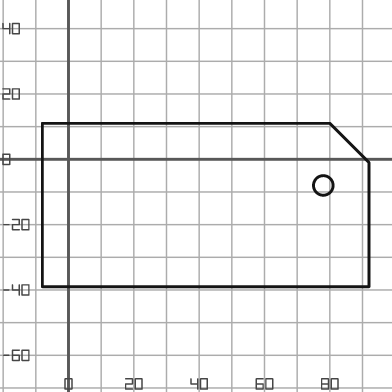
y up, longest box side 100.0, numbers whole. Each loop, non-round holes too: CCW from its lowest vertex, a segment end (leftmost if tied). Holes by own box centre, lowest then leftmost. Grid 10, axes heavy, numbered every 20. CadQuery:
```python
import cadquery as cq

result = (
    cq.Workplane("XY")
    .moveTo(-8.0, -39.0)
    .lineTo(92.0, -39.0)
    .lineTo(92.0, -1.0)
    .lineTo(80.0, 11.0)
    .lineTo(-8.0, 11.0)
    .close()
    .moveTo(78.0, -8.0)
    .circle(3.0)
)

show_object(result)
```